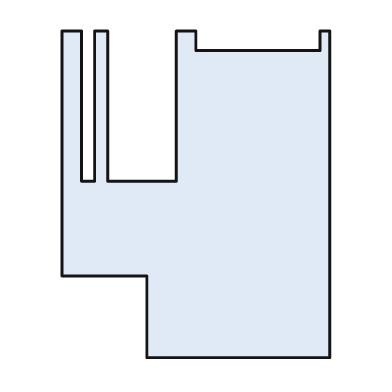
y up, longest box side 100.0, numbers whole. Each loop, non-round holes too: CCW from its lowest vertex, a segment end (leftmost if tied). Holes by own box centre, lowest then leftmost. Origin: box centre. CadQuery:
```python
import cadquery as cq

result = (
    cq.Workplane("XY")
    .moveTo(-15.0, -50.0)
    .lineTo(41.0, -50.0)
    .lineTo(41.0, 50.0)
    .lineTo(38.0, 50.0)
    .lineTo(38.0, 44.0)
    .lineTo(0.0, 44.0)
    .lineTo(0.0, 50.0)
    .lineTo(-6.0, 50.0)
    .lineTo(-6.0, 4.0)
    .lineTo(-27.0, 4.0)
    .lineTo(-27.0, 50.0)
    .lineTo(-31.0, 50.0)
    .lineTo(-31.0, 4.0)
    .lineTo(-35.0, 4.0)
    .lineTo(-35.0, 50.0)
    .lineTo(-41.0, 50.0)
    .lineTo(-41.0, -25.0)
    .lineTo(-15.0, -25.0)
    .close()
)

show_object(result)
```